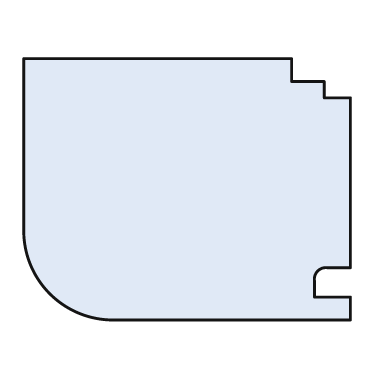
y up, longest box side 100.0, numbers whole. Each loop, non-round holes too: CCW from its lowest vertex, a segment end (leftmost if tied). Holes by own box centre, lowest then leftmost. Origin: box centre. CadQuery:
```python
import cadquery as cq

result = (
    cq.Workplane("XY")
    .moveTo(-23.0, -40.0)
    .lineTo(50.0, -40.0)
    .lineTo(50.0, -33.0)
    .lineTo(39.0, -33.0)
    .lineTo(39.0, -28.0)
    .threePointArc((40.0, -25.0), (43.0, -24.0))
    .lineTo(50.0, -24.0)
    .lineTo(50.0, 28.0)
    .lineTo(42.0, 28.0)
    .lineTo(42.0, 33.0)
    .lineTo(32.0, 33.0)
    .lineTo(32.0, 40.0)
    .lineTo(-50.0, 40.0)
    .lineTo(-50.0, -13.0)
    .threePointArc((-42.0, -32.0), (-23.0, -40.0))
    .close()
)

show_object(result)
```